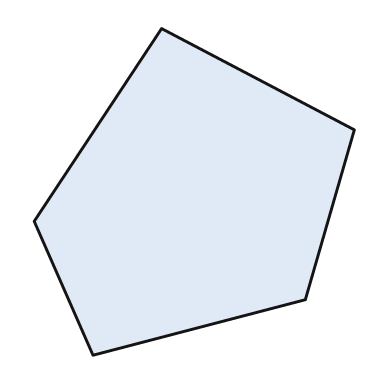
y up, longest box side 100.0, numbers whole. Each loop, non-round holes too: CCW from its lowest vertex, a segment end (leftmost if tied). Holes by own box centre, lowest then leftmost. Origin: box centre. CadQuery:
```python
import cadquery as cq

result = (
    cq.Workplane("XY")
    .moveTo(-31.0, -50.0)
    .lineTo(34.0, -33.0)
    .lineTo(49.0, 19.0)
    .lineTo(-10.0, 50.0)
    .lineTo(-49.0, -9.0)
    .close()
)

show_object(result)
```